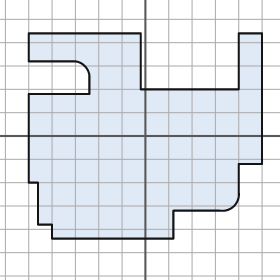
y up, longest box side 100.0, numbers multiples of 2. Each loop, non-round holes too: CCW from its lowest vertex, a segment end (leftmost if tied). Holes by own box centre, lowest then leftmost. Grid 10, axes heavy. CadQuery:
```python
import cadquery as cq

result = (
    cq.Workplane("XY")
    .moveTo(-40.0, -44.0)
    .lineTo(12.0, -44.0)
    .lineTo(12.0, -32.0)
    .lineTo(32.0, -32.0)
    .threePointArc((38.0, -30.0), (40.0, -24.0))
    .lineTo(40.0, -12.0)
    .lineTo(50.0, -12.0)
    .lineTo(50.0, 44.0)
    .lineTo(40.0, 44.0)
    .lineTo(40.0, 20.0)
    .lineTo(-2.0, 20.0)
    .lineTo(-2.0, 44.0)
    .lineTo(-50.0, 44.0)
    .lineTo(-50.0, 32.0)
    .lineTo(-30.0, 32.0)
    .threePointArc((-26.0, 30.0), (-24.0, 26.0))
    .lineTo(-24.0, 18.0)
    .lineTo(-50.0, 18.0)
    .lineTo(-50.0, -20.0)
    .lineTo(-46.0, -20.0)
    .lineTo(-46.0, -38.0)
    .lineTo(-40.0, -38.0)
    .close()
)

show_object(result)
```